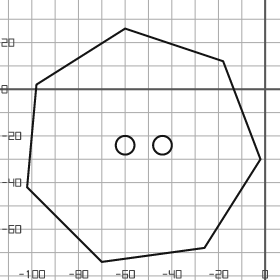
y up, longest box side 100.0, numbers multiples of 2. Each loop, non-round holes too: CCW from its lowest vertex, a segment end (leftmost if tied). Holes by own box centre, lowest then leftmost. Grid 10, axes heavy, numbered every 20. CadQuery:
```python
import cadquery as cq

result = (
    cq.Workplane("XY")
    .moveTo(-70.0, -74.0)
    .lineTo(-26.0, -68.0)
    .lineTo(-2.0, -30.0)
    .lineTo(-18.0, 12.0)
    .lineTo(-60.0, 26.0)
    .lineTo(-98.0, 2.0)
    .lineTo(-102.0, -42.0)
    .close()
    .moveTo(-60.0, -24.0)
    .circle(4.0)
    .moveTo(-44.0, -24.0)
    .circle(4.0)
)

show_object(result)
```